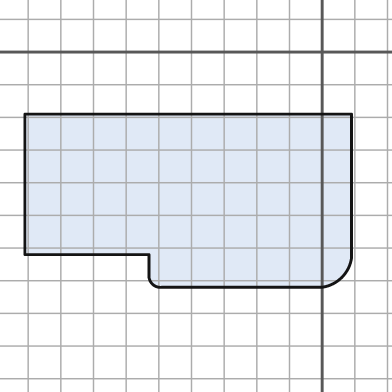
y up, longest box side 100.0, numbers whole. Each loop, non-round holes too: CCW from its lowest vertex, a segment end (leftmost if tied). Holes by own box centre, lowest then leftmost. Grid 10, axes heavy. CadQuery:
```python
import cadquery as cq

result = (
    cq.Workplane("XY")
    .moveTo(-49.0, -72.0)
    .lineTo(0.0, -72.0)
    .threePointArc((6.0, -69.0), (9.0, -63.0))
    .lineTo(9.0, -19.0)
    .lineTo(-91.0, -19.0)
    .lineTo(-91.0, -62.0)
    .lineTo(-53.0, -62.0)
    .lineTo(-53.0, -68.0)
    .threePointArc((-52.0, -71.0), (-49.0, -72.0))
    .close()
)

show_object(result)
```